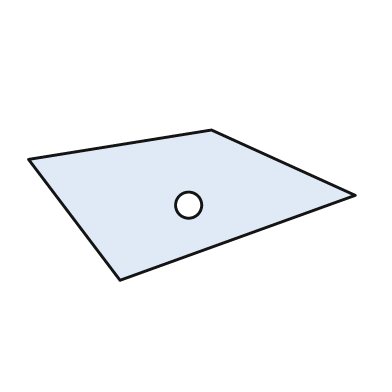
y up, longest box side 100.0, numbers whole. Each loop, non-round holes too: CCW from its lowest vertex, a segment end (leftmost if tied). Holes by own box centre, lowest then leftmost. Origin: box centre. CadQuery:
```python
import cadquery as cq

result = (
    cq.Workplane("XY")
    .moveTo(-22.0, -23.0)
    .lineTo(50.0, 3.0)
    .lineTo(6.0, 23.0)
    .lineTo(-50.0, 14.0)
    .close()
    .moveTo(-1.0, 0.0)
    .circle(4.0)
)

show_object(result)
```